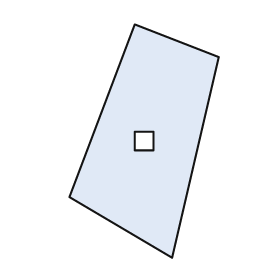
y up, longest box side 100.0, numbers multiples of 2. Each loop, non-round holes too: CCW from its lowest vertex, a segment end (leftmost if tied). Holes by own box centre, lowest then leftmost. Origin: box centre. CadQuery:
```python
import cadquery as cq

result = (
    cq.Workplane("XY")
    .moveTo(12.0, -50.0)
    .lineTo(32.0, 36.0)
    .lineTo(-4.0, 50.0)
    .lineTo(-32.0, -24.0)
    .close()
    .moveTo(-4.0, -4.0)
    .lineTo(4.0, -4.0)
    .lineTo(4.0, 4.0)
    .lineTo(-4.0, 4.0)
    .close()
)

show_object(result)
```